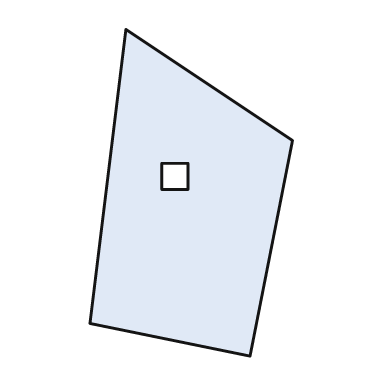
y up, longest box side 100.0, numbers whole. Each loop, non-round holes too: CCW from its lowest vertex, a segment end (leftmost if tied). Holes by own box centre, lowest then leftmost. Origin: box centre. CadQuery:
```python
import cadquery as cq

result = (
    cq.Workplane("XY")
    .moveTo(18.0, -50.0)
    .lineTo(31.0, 16.0)
    .lineTo(-20.0, 50.0)
    .lineTo(-31.0, -40.0)
    .close()
    .moveTo(-9.0, 1.0)
    .lineTo(-1.0, 1.0)
    .lineTo(-1.0, 9.0)
    .lineTo(-9.0, 9.0)
    .close()
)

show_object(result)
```